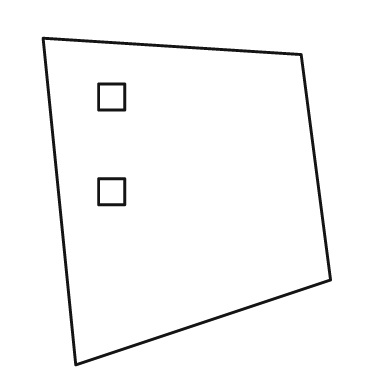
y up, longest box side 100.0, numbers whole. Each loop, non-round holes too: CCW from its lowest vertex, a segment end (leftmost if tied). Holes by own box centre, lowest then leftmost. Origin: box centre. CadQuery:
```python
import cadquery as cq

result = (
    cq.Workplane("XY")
    .moveTo(-34.0, -50.0)
    .lineTo(44.0, -24.0)
    .lineTo(35.0, 45.0)
    .lineTo(-44.0, 50.0)
    .close()
    .moveTo(-27.0, -1.0)
    .lineTo(-19.0, -1.0)
    .lineTo(-19.0, 7.0)
    .lineTo(-27.0, 7.0)
    .close()
    .moveTo(-27.0, 28.0)
    .lineTo(-19.0, 28.0)
    .lineTo(-19.0, 36.0)
    .lineTo(-27.0, 36.0)
    .close()
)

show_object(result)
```